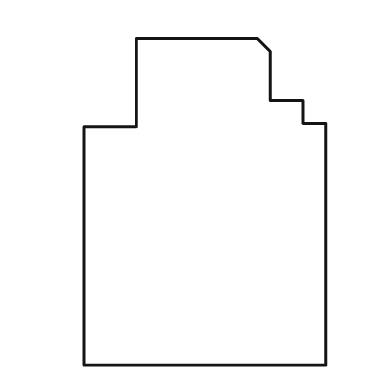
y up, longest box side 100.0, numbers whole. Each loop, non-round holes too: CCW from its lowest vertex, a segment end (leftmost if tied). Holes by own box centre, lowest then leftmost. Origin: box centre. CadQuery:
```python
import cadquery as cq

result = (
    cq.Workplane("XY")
    .moveTo(-37.0, -50.0)
    .lineTo(37.0, -50.0)
    .lineTo(37.0, 24.0)
    .lineTo(30.0, 24.0)
    .lineTo(30.0, 31.0)
    .lineTo(20.0, 31.0)
    .lineTo(20.0, 46.0)
    .lineTo(16.0, 50.0)
    .lineTo(-21.0, 50.0)
    .lineTo(-21.0, 23.0)
    .lineTo(-37.0, 23.0)
    .close()
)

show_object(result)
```